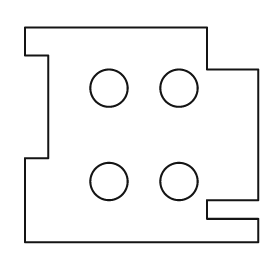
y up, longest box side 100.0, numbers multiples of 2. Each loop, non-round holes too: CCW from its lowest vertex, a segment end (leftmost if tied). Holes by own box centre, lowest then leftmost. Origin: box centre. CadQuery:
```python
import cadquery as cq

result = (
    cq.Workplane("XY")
    .moveTo(-50.0, -46.0)
    .lineTo(50.0, -46.0)
    .lineTo(50.0, -36.0)
    .lineTo(28.0, -36.0)
    .lineTo(28.0, -28.0)
    .lineTo(50.0, -28.0)
    .lineTo(50.0, 28.0)
    .lineTo(28.0, 28.0)
    .lineTo(28.0, 46.0)
    .lineTo(-50.0, 46.0)
    .lineTo(-50.0, 34.0)
    .lineTo(-40.0, 34.0)
    .lineTo(-40.0, -10.0)
    .lineTo(-50.0, -10.0)
    .close()
    .moveTo(-14.0, -20.0)
    .circle(8.0)
    .moveTo(16.0, -20.0)
    .circle(8.0)
    .moveTo(-14.0, 20.0)
    .circle(8.0)
    .moveTo(16.0, 20.0)
    .circle(8.0)
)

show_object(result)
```